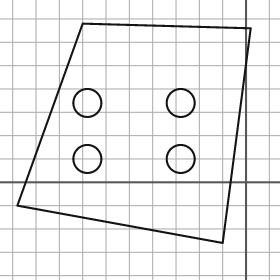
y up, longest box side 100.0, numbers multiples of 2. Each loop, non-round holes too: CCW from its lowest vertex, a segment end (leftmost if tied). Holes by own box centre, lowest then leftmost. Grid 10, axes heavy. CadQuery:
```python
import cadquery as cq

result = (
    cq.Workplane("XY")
    .moveTo(-10.0, -26.0)
    .lineTo(2.0, 66.0)
    .lineTo(-70.0, 68.0)
    .lineTo(-98.0, -10.0)
    .close()
    .moveTo(-68.0, 10.0)
    .circle(6.0)
    .moveTo(-28.0, 10.0)
    .circle(6.0)
    .moveTo(-68.0, 34.0)
    .circle(6.0)
    .moveTo(-28.0, 34.0)
    .circle(6.0)
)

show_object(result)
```